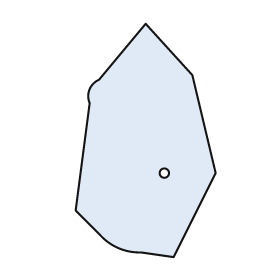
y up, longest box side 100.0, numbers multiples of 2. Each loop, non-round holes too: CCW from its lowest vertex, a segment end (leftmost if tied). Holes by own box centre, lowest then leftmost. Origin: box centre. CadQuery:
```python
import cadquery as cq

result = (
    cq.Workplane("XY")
    .moveTo(12.0, -50.0)
    .lineTo(30.0, -14.0)
    .lineTo(20.0, 28.0)
    .lineTo(0.0, 50.0)
    .lineTo(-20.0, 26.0)
    .threePointArc((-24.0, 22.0), (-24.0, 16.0))
    .lineTo(-30.0, -30.0)
    .lineTo(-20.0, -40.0)
    .threePointArc((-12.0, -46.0), (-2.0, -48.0))
    .close()
    .moveTo(8.0, -14.0)
    .circle(2.0)
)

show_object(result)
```